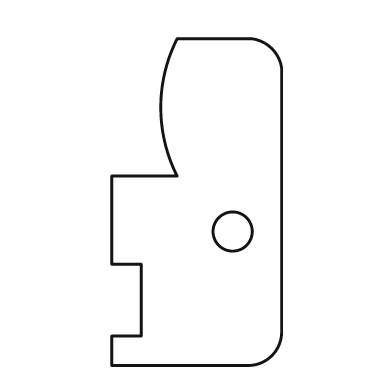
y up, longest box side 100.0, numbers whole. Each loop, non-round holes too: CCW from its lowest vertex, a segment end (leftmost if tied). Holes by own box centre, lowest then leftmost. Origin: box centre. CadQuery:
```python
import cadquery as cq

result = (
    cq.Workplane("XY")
    .moveTo(-26.0, -50.0)
    .lineTo(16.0, -50.0)
    .threePointArc((23.0, -47.0), (26.0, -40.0))
    .lineTo(26.0, 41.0)
    .threePointArc((23.0, 47.0), (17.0, 50.0))
    .lineTo(-6.0, 50.0)
    .threePointArc((-11.0, 29.0), (-6.0, 8.0))
    .lineTo(-26.0, 8.0)
    .lineTo(-26.0, -19.0)
    .lineTo(-17.0, -19.0)
    .lineTo(-17.0, -41.0)
    .lineTo(-26.0, -41.0)
    .close()
    .moveTo(11.0, -9.0)
    .circle(6.0)
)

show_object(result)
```